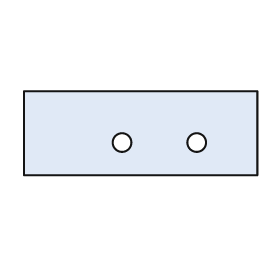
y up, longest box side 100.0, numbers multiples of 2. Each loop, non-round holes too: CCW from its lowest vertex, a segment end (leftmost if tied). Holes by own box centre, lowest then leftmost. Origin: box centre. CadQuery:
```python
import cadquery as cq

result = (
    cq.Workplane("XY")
    .moveTo(-50.0, -18.0)
    .lineTo(50.0, -18.0)
    .lineTo(50.0, 18.0)
    .lineTo(-50.0, 18.0)
    .close()
    .moveTo(-8.0, -4.0)
    .circle(4.0)
    .moveTo(24.0, -4.0)
    .circle(4.0)
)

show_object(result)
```